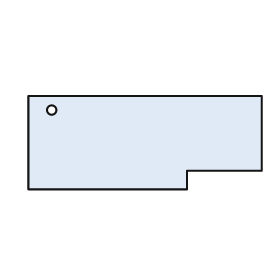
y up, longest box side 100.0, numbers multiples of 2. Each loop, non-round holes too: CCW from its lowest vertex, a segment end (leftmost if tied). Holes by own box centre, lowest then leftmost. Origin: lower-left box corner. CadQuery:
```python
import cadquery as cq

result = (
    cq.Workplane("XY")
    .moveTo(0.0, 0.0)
    .lineTo(68.0, 0.0)
    .lineTo(68.0, 8.0)
    .lineTo(100.0, 8.0)
    .lineTo(100.0, 40.0)
    .lineTo(0.0, 40.0)
    .close()
    .moveTo(10.0, 34.0)
    .circle(2.0)
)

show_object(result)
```